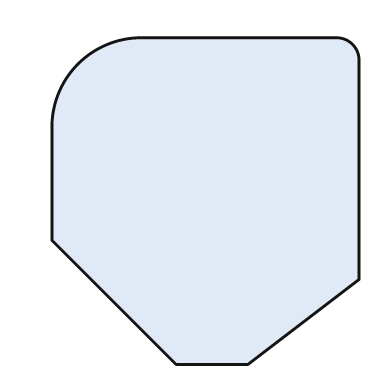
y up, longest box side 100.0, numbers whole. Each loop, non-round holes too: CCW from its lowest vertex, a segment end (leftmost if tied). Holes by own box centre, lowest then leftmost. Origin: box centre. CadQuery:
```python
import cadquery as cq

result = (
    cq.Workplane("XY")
    .moveTo(-9.0, -50.0)
    .lineTo(13.0, -50.0)
    .lineTo(47.0, -24.0)
    .lineTo(47.0, 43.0)
    .threePointArc((45.0, 48.0), (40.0, 50.0))
    .lineTo(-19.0, 50.0)
    .threePointArc((-39.0, 42.0), (-47.0, 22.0))
    .lineTo(-47.0, -12.0)
    .close()
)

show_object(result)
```